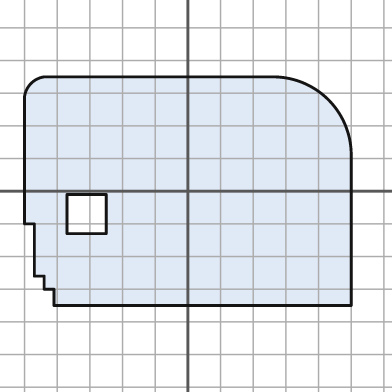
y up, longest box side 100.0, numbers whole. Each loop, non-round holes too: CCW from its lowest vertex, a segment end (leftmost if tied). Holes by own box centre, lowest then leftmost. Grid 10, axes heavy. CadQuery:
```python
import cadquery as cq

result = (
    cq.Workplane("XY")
    .moveTo(-41.0, -35.0)
    .lineTo(50.0, -35.0)
    .lineTo(50.0, 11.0)
    .threePointArc((43.0, 28.0), (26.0, 35.0))
    .lineTo(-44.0, 35.0)
    .threePointArc((-48.0, 33.0), (-50.0, 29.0))
    .lineTo(-50.0, -10.0)
    .lineTo(-47.0, -10.0)
    .lineTo(-47.0, -26.0)
    .lineTo(-44.0, -26.0)
    .lineTo(-44.0, -30.0)
    .lineTo(-41.0, -30.0)
    .close()
    .moveTo(-37.0, -13.0)
    .lineTo(-25.0, -13.0)
    .lineTo(-25.0, -1.0)
    .lineTo(-37.0, -1.0)
    .close()
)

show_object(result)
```